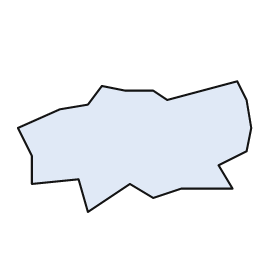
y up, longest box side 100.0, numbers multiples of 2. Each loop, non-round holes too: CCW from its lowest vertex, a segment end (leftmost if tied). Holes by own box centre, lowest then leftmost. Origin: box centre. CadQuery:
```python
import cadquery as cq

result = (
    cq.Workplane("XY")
    .moveTo(-20.0, -28.0)
    .lineTo(-2.0, -16.0)
    .lineTo(8.0, -22.0)
    .lineTo(20.0, -18.0)
    .lineTo(42.0, -18.0)
    .lineTo(36.0, -8.0)
    .lineTo(48.0, -2.0)
    .lineTo(50.0, 8.0)
    .lineTo(48.0, 20.0)
    .lineTo(44.0, 28.0)
    .lineTo(14.0, 20.0)
    .lineTo(8.0, 24.0)
    .lineTo(-4.0, 24.0)
    .lineTo(-14.0, 26.0)
    .lineTo(-20.0, 18.0)
    .lineTo(-32.0, 16.0)
    .lineTo(-50.0, 8.0)
    .lineTo(-44.0, -4.0)
    .lineTo(-44.0, -16.0)
    .lineTo(-24.0, -14.0)
    .close()
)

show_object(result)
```